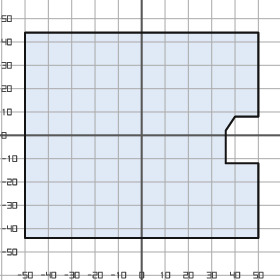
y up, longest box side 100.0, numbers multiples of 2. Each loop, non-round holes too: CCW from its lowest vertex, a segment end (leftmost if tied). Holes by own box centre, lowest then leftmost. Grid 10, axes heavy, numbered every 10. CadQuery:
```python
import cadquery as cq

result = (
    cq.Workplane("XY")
    .moveTo(-50.0, -44.0)
    .lineTo(50.0, -44.0)
    .lineTo(50.0, -12.0)
    .lineTo(36.0, -12.0)
    .lineTo(36.0, 2.0)
    .lineTo(40.0, 8.0)
    .lineTo(50.0, 8.0)
    .lineTo(50.0, 44.0)
    .lineTo(-50.0, 44.0)
    .close()
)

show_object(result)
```